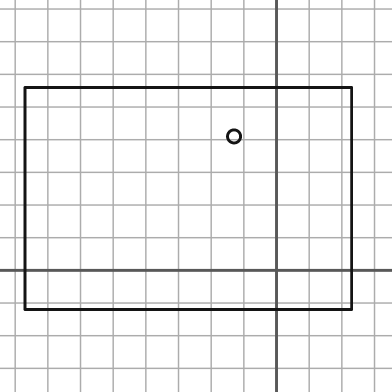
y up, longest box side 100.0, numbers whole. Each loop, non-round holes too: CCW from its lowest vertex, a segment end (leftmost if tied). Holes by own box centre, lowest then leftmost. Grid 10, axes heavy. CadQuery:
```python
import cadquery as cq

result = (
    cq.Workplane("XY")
    .moveTo(-77.0, -12.0)
    .lineTo(23.0, -12.0)
    .lineTo(23.0, 56.0)
    .lineTo(-77.0, 56.0)
    .close()
    .moveTo(-13.0, 41.0)
    .circle(2.0)
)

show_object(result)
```